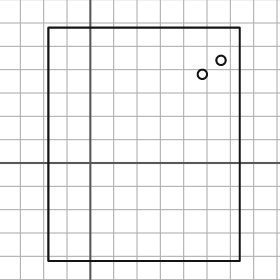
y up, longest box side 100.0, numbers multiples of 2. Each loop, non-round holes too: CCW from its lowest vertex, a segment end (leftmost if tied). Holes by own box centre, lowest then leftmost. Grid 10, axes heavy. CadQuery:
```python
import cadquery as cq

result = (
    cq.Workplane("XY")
    .moveTo(-18.0, -42.0)
    .lineTo(64.0, -42.0)
    .lineTo(64.0, 58.0)
    .lineTo(-18.0, 58.0)
    .close()
    .moveTo(48.0, 38.0)
    .circle(2.0)
    .moveTo(56.0, 44.0)
    .circle(2.0)
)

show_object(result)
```